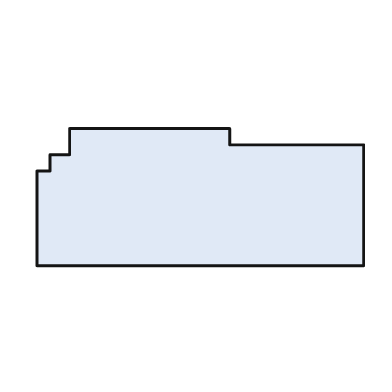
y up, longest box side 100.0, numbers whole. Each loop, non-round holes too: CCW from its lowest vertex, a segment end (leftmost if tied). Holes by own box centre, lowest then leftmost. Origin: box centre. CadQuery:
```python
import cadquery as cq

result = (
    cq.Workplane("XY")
    .moveTo(-50.0, -21.0)
    .lineTo(50.0, -21.0)
    .lineTo(50.0, 16.0)
    .lineTo(9.0, 16.0)
    .lineTo(9.0, 21.0)
    .lineTo(-40.0, 21.0)
    .lineTo(-40.0, 13.0)
    .lineTo(-46.0, 13.0)
    .lineTo(-46.0, 8.0)
    .lineTo(-50.0, 8.0)
    .close()
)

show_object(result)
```